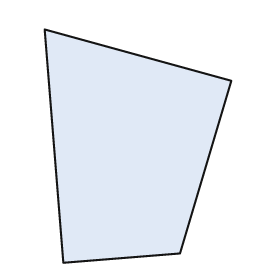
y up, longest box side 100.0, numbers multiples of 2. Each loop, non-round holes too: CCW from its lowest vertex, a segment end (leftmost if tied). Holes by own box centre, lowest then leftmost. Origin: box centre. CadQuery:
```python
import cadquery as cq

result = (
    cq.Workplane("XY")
    .moveTo(-32.0, -50.0)
    .lineTo(18.0, -46.0)
    .lineTo(40.0, 28.0)
    .lineTo(-40.0, 50.0)
    .close()
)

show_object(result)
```